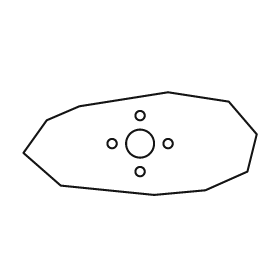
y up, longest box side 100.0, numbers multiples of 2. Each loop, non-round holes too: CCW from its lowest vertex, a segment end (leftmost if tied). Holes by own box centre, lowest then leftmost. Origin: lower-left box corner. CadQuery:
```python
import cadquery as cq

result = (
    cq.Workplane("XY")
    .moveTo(56.0, 0.0)
    .lineTo(78.0, 2.0)
    .lineTo(96.0, 10.0)
    .lineTo(100.0, 26.0)
    .lineTo(88.0, 40.0)
    .lineTo(62.0, 44.0)
    .lineTo(24.0, 38.0)
    .lineTo(10.0, 32.0)
    .lineTo(0.0, 18.0)
    .lineTo(16.0, 4.0)
    .close()
    .moveTo(50.0, 10.0)
    .circle(2.0)
    .moveTo(38.0, 22.0)
    .circle(2.0)
    .moveTo(50.0, 22.0)
    .circle(6.0)
    .moveTo(62.0, 22.0)
    .circle(2.0)
    .moveTo(50.0, 34.0)
    .circle(2.0)
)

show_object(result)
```